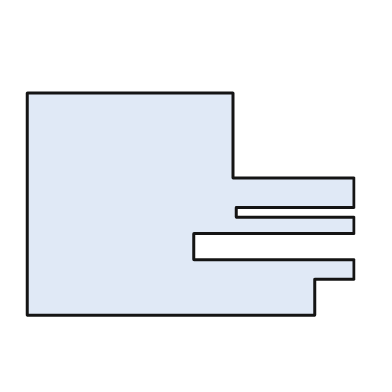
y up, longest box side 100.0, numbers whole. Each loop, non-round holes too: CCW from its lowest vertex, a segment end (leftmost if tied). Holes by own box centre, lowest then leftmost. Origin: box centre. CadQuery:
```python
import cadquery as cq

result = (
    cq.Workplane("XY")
    .moveTo(-50.0, -34.0)
    .lineTo(38.0, -34.0)
    .lineTo(38.0, -23.0)
    .lineTo(50.0, -23.0)
    .lineTo(50.0, -17.0)
    .lineTo(1.0, -17.0)
    .lineTo(1.0, -9.0)
    .lineTo(50.0, -9.0)
    .lineTo(50.0, -4.0)
    .lineTo(14.0, -4.0)
    .lineTo(14.0, -1.0)
    .lineTo(50.0, -1.0)
    .lineTo(50.0, 8.0)
    .lineTo(13.0, 8.0)
    .lineTo(13.0, 34.0)
    .lineTo(-50.0, 34.0)
    .close()
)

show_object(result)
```